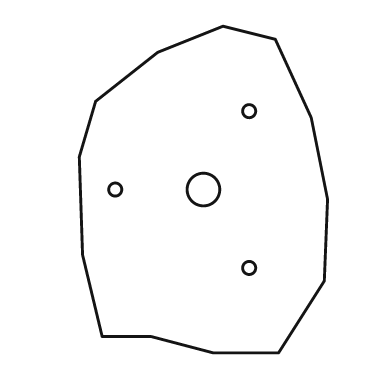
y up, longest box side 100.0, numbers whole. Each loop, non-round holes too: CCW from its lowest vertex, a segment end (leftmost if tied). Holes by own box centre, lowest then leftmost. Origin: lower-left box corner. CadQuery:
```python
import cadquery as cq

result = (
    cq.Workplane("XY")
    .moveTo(41.0, 0.0)
    .lineTo(61.0, 0.0)
    .lineTo(75.0, 22.0)
    .lineTo(76.0, 47.0)
    .lineTo(71.0, 72.0)
    .lineTo(60.0, 96.0)
    .lineTo(44.0, 100.0)
    .lineTo(24.0, 92.0)
    .lineTo(5.0, 77.0)
    .lineTo(0.0, 60.0)
    .lineTo(1.0, 30.0)
    .lineTo(7.0, 5.0)
    .lineTo(22.0, 5.0)
    .close()
    .moveTo(52.0, 26.0)
    .circle(2.0)
    .moveTo(11.0, 50.0)
    .circle(2.0)
    .moveTo(38.0, 50.0)
    .circle(5.0)
    .moveTo(52.0, 74.0)
    .circle(2.0)
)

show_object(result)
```